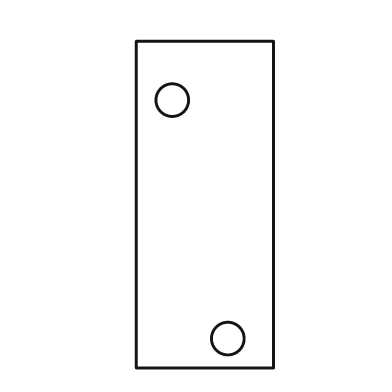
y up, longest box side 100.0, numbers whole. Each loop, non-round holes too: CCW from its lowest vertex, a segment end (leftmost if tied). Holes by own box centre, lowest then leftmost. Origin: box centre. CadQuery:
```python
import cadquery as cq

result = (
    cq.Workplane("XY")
    .moveTo(-21.0, -50.0)
    .lineTo(21.0, -50.0)
    .lineTo(21.0, 50.0)
    .lineTo(-21.0, 50.0)
    .close()
    .moveTo(7.0, -41.0)
    .circle(5.0)
    .moveTo(-10.0, 32.0)
    .circle(5.0)
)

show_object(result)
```